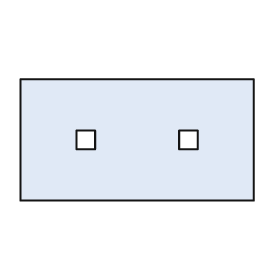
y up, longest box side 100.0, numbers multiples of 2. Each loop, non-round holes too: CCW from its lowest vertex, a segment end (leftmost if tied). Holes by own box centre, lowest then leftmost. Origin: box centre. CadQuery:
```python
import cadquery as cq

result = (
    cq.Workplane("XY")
    .moveTo(-50.0, -26.0)
    .lineTo(50.0, -26.0)
    .lineTo(50.0, 26.0)
    .lineTo(-50.0, 26.0)
    .close()
    .moveTo(-26.0, -4.0)
    .lineTo(-18.0, -4.0)
    .lineTo(-18.0, 4.0)
    .lineTo(-26.0, 4.0)
    .close()
    .moveTo(18.0, -4.0)
    .lineTo(26.0, -4.0)
    .lineTo(26.0, 4.0)
    .lineTo(18.0, 4.0)
    .close()
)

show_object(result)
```